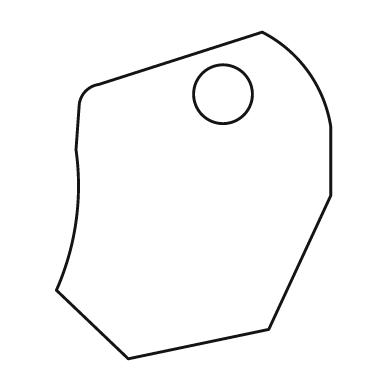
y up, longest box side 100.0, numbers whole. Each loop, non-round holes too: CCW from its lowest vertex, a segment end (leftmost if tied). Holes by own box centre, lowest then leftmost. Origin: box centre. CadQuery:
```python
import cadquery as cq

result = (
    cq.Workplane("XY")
    .moveTo(-20.0, -50.0)
    .lineTo(23.0, -41.0)
    .lineTo(42.0, 0.0)
    .lineTo(42.0, 21.0)
    .threePointArc((35.0, 38.0), (21.0, 50.0))
    .lineTo(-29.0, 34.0)
    .threePointArc((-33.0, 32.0), (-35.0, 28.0))
    .lineTo(-36.0, 14.0)
    .threePointArc((-36.0, -8.0), (-42.0, -29.0))
    .close()
    .moveTo(9.0, 31.0)
    .circle(9.0)
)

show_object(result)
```